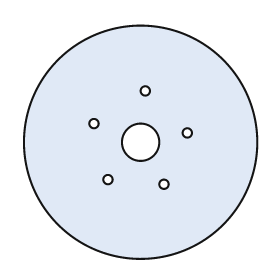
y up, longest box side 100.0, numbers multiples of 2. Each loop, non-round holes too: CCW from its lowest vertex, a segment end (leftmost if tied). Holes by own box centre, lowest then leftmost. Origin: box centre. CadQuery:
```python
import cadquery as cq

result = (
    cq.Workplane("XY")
    .moveTo(0.0, 0.0)
    .circle(50.0)
    .moveTo(10.0, -18.0)
    .circle(2.0)
    .moveTo(-14.0, -16.0)
    .circle(2.0)
    .moveTo(0.0, 0.0)
    .circle(8.0)
    .moveTo(20.0, 4.0)
    .circle(2.0)
    .moveTo(-20.0, 8.0)
    .circle(2.0)
    .moveTo(2.0, 22.0)
    .circle(2.0)
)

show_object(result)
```